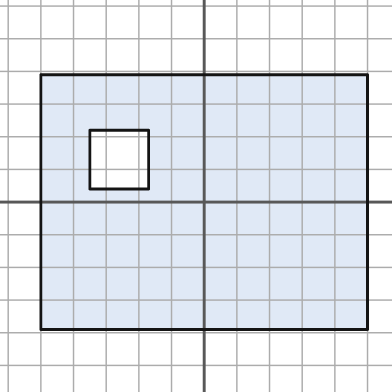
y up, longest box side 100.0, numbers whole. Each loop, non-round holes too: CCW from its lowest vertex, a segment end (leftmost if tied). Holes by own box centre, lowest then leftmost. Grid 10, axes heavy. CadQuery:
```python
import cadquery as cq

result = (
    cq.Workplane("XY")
    .moveTo(-50.0, -39.0)
    .lineTo(50.0, -39.0)
    .lineTo(50.0, 39.0)
    .lineTo(-50.0, 39.0)
    .close()
    .moveTo(-35.0, 4.0)
    .lineTo(-17.0, 4.0)
    .lineTo(-17.0, 22.0)
    .lineTo(-35.0, 22.0)
    .close()
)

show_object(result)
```